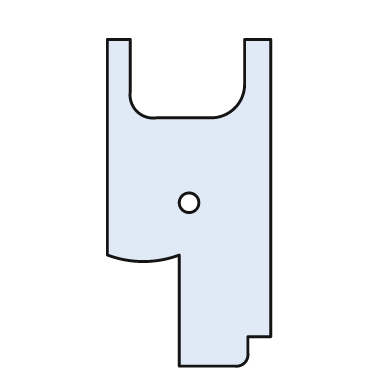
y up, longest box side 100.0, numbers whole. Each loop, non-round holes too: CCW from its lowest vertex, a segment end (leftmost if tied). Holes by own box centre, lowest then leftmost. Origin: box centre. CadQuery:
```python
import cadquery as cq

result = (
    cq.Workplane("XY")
    .moveTo(-3.0, -50.0)
    .lineTo(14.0, -50.0)
    .threePointArc((17.0, -49.0), (18.0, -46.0))
    .lineTo(18.0, -41.0)
    .lineTo(25.0, -41.0)
    .lineTo(25.0, 50.0)
    .lineTo(17.0, 50.0)
    .lineTo(17.0, 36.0)
    .threePointArc((14.0, 29.0), (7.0, 26.0))
    .lineTo(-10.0, 26.0)
    .threePointArc((-16.0, 28.0), (-18.0, 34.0))
    .lineTo(-18.0, 50.0)
    .lineTo(-25.0, 50.0)
    .lineTo(-25.0, -16.0)
    .threePointArc((-14.0, -18.0), (-3.0, -16.0))
    .close()
    .moveTo(0.0, 0.0)
    .circle(3.0)
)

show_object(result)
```